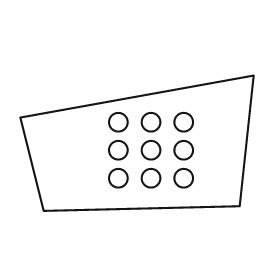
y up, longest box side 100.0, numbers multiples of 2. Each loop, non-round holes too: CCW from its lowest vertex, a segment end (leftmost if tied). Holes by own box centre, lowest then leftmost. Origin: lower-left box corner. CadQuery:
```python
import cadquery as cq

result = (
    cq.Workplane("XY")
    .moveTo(10.0, 0.0)
    .lineTo(94.0, 2.0)
    .lineTo(100.0, 58.0)
    .lineTo(0.0, 40.0)
    .close()
    .moveTo(42.0, 14.0)
    .circle(4.0)
    .moveTo(56.0, 14.0)
    .circle(4.0)
    .moveTo(70.0, 14.0)
    .circle(4.0)
    .moveTo(42.0, 26.0)
    .circle(4.0)
    .moveTo(56.0, 26.0)
    .circle(4.0)
    .moveTo(70.0, 26.0)
    .circle(4.0)
    .moveTo(42.0, 38.0)
    .circle(4.0)
    .moveTo(56.0, 38.0)
    .circle(4.0)
    .moveTo(70.0, 38.0)
    .circle(4.0)
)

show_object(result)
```